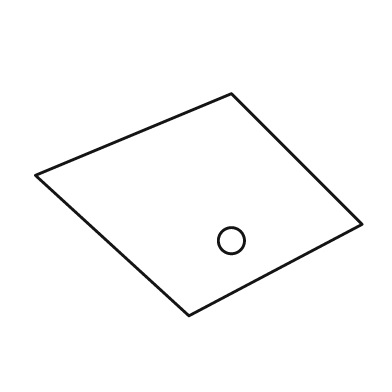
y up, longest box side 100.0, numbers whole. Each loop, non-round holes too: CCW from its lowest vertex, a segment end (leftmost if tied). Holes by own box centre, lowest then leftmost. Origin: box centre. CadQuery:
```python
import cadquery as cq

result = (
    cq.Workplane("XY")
    .moveTo(-3.0, -34.0)
    .lineTo(50.0, -6.0)
    .lineTo(10.0, 34.0)
    .lineTo(-50.0, 9.0)
    .close()
    .moveTo(10.0, -11.0)
    .circle(4.0)
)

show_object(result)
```